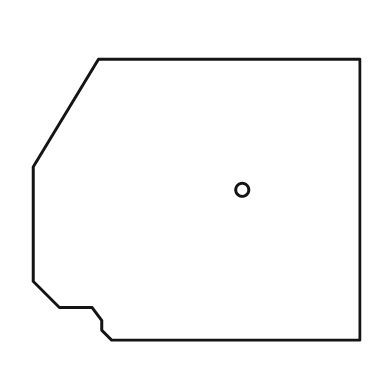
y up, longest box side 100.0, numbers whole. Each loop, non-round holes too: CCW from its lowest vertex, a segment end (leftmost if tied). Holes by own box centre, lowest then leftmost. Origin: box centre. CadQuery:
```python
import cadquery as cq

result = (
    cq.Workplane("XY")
    .moveTo(-26.0, -43.0)
    .lineTo(50.0, -43.0)
    .lineTo(50.0, 43.0)
    .lineTo(-30.0, 43.0)
    .lineTo(-50.0, 10.0)
    .lineTo(-50.0, -25.0)
    .lineTo(-42.0, -33.0)
    .lineTo(-32.0, -33.0)
    .lineTo(-29.0, -37.0)
    .lineTo(-29.0, -40.0)
    .close()
    .moveTo(14.0, 3.0)
    .circle(2.0)
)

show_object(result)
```